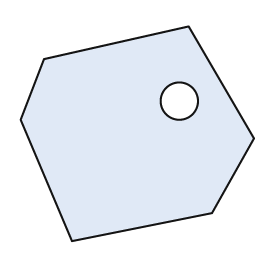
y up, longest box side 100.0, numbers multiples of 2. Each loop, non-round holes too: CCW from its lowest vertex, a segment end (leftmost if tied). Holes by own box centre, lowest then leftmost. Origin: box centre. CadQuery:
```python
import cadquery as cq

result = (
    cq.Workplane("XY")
    .moveTo(-28.0, -46.0)
    .lineTo(32.0, -34.0)
    .lineTo(50.0, -2.0)
    .lineTo(22.0, 46.0)
    .lineTo(-40.0, 32.0)
    .lineTo(-50.0, 6.0)
    .close()
    .moveTo(18.0, 14.0)
    .circle(8.0)
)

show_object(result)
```